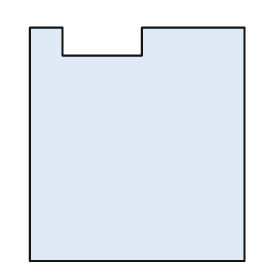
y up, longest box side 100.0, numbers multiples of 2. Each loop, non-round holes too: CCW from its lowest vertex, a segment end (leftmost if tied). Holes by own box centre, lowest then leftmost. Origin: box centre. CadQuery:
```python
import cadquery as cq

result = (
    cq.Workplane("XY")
    .moveTo(-46.0, -50.0)
    .lineTo(46.0, -50.0)
    .lineTo(46.0, 50.0)
    .lineTo(2.0, 50.0)
    .lineTo(2.0, 38.0)
    .lineTo(-32.0, 38.0)
    .lineTo(-32.0, 50.0)
    .lineTo(-46.0, 50.0)
    .close()
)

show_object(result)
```